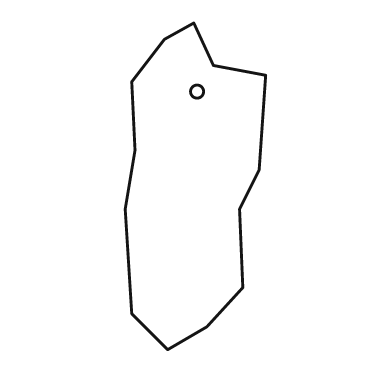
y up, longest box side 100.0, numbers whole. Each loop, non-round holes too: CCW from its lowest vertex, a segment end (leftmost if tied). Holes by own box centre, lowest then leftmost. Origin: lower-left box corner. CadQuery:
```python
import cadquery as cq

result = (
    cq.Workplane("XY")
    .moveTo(13.0, 0.0)
    .lineTo(25.0, 7.0)
    .lineTo(36.0, 19.0)
    .lineTo(35.0, 43.0)
    .lineTo(41.0, 55.0)
    .lineTo(43.0, 84.0)
    .lineTo(27.0, 87.0)
    .lineTo(21.0, 100.0)
    .lineTo(12.0, 95.0)
    .lineTo(2.0, 82.0)
    .lineTo(3.0, 61.0)
    .lineTo(0.0, 43.0)
    .lineTo(2.0, 11.0)
    .close()
    .moveTo(22.0, 79.0)
    .circle(2.0)
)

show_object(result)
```